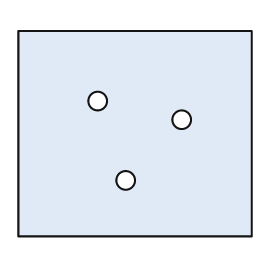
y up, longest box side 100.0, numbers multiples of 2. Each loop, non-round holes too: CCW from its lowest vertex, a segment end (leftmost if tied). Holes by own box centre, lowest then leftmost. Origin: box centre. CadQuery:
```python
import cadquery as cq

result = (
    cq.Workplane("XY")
    .moveTo(-50.0, -44.0)
    .lineTo(50.0, -44.0)
    .lineTo(50.0, 44.0)
    .lineTo(-50.0, 44.0)
    .close()
    .moveTo(-4.0, -20.0)
    .circle(4.0)
    .moveTo(20.0, 6.0)
    .circle(4.0)
    .moveTo(-16.0, 14.0)
    .circle(4.0)
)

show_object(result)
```